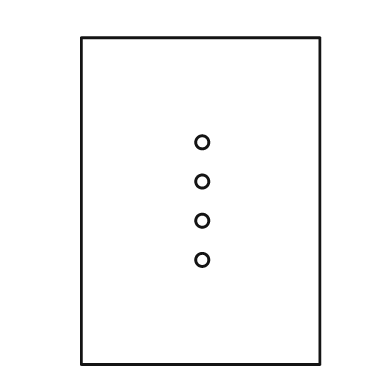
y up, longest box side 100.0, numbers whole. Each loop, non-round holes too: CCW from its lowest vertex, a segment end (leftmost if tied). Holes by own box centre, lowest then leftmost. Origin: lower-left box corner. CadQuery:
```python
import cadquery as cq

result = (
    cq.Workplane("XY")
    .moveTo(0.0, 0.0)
    .lineTo(73.0, 0.0)
    .lineTo(73.0, 100.0)
    .lineTo(0.0, 100.0)
    .close()
    .moveTo(37.0, 32.0)
    .circle(2.0)
    .moveTo(37.0, 44.0)
    .circle(2.0)
    .moveTo(37.0, 56.0)
    .circle(2.0)
    .moveTo(37.0, 68.0)
    .circle(2.0)
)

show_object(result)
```